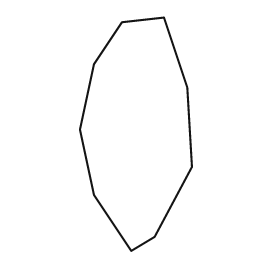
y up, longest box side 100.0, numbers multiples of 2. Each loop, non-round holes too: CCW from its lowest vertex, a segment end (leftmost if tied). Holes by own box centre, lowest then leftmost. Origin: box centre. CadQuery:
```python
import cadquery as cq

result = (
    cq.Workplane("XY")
    .moveTo(-2.0, -50.0)
    .lineTo(8.0, -44.0)
    .lineTo(24.0, -14.0)
    .lineTo(22.0, 20.0)
    .lineTo(12.0, 50.0)
    .lineTo(-6.0, 48.0)
    .lineTo(-18.0, 30.0)
    .lineTo(-24.0, 2.0)
    .lineTo(-18.0, -26.0)
    .close()
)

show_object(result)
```